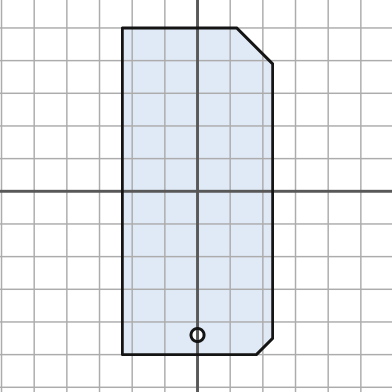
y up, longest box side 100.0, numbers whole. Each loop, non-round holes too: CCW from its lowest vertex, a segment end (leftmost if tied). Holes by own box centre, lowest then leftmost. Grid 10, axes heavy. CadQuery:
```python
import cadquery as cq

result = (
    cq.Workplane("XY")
    .moveTo(-23.0, -50.0)
    .lineTo(18.0, -50.0)
    .lineTo(23.0, -45.0)
    .lineTo(23.0, 39.0)
    .lineTo(12.0, 50.0)
    .lineTo(-23.0, 50.0)
    .close()
    .moveTo(0.0, -44.0)
    .circle(2.0)
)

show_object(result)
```